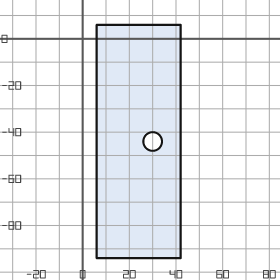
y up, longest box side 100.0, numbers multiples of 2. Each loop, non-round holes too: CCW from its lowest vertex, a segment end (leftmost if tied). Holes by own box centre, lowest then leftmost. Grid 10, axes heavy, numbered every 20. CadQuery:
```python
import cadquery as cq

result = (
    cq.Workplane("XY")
    .moveTo(6.0, -94.0)
    .lineTo(42.0, -94.0)
    .lineTo(42.0, 6.0)
    .lineTo(6.0, 6.0)
    .close()
    .moveTo(30.0, -44.0)
    .circle(4.0)
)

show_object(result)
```